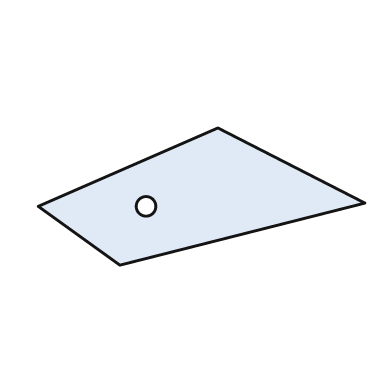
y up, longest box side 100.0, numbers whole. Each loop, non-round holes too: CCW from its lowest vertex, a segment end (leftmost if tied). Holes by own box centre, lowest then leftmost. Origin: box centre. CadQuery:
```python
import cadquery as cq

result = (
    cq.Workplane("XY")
    .moveTo(-25.0, -21.0)
    .lineTo(50.0, -2.0)
    .lineTo(5.0, 21.0)
    .lineTo(-50.0, -3.0)
    .close()
    .moveTo(-17.0, -3.0)
    .circle(3.0)
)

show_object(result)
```